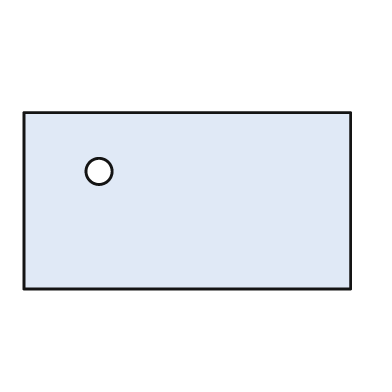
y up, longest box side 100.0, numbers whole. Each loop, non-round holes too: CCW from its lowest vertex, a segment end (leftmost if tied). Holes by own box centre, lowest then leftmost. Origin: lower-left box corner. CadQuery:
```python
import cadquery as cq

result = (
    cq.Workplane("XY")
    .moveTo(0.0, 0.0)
    .lineTo(100.0, 0.0)
    .lineTo(100.0, 54.0)
    .lineTo(0.0, 54.0)
    .close()
    .moveTo(23.0, 36.0)
    .circle(4.0)
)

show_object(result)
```